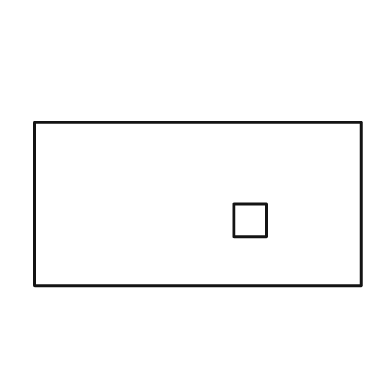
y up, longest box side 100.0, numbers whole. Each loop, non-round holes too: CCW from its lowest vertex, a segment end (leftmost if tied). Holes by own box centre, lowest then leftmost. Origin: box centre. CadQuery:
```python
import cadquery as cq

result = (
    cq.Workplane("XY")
    .moveTo(-50.0, -25.0)
    .lineTo(50.0, -25.0)
    .lineTo(50.0, 25.0)
    .lineTo(-50.0, 25.0)
    .close()
    .moveTo(11.0, -10.0)
    .lineTo(21.0, -10.0)
    .lineTo(21.0, 0.0)
    .lineTo(11.0, 0.0)
    .close()
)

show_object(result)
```